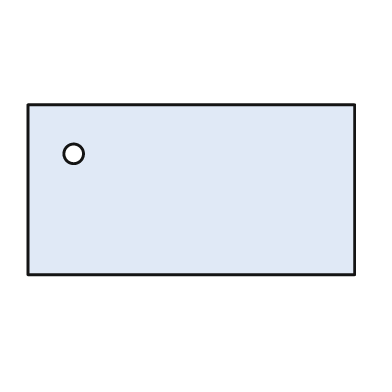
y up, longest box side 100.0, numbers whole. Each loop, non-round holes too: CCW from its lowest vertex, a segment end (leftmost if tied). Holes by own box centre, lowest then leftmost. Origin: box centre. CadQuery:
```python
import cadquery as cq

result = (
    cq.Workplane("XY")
    .moveTo(-50.0, -26.0)
    .lineTo(50.0, -26.0)
    .lineTo(50.0, 26.0)
    .lineTo(-50.0, 26.0)
    .close()
    .moveTo(-36.0, 11.0)
    .circle(3.0)
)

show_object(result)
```